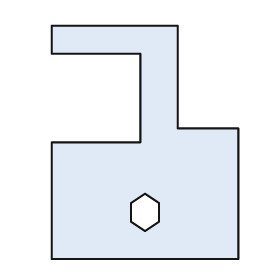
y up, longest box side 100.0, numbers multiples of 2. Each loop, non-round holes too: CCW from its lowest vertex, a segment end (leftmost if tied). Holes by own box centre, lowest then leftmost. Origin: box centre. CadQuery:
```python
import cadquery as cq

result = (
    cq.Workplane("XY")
    .moveTo(-40.0, -50.0)
    .lineTo(40.0, -50.0)
    .lineTo(40.0, 6.0)
    .lineTo(14.0, 6.0)
    .lineTo(14.0, 50.0)
    .lineTo(-40.0, 50.0)
    .lineTo(-40.0, 38.0)
    .lineTo(-2.0, 38.0)
    .lineTo(-2.0, 0.0)
    .lineTo(-40.0, 0.0)
    .close()
    .moveTo(0.0, -38.0)
    .lineTo(6.0, -34.0)
    .lineTo(6.0, -26.0)
    .lineTo(0.0, -22.0)
    .lineTo(-6.0, -26.0)
    .lineTo(-6.0, -34.0)
    .close()
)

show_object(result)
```